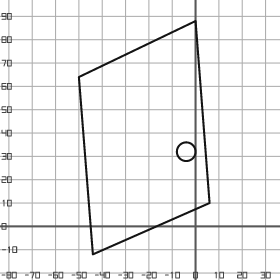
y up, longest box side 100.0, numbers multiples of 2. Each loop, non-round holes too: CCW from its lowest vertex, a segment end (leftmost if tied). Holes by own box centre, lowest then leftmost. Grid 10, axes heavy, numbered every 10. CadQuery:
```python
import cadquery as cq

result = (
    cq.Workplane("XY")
    .moveTo(-44.0, -12.0)
    .lineTo(6.0, 10.0)
    .lineTo(0.0, 88.0)
    .lineTo(-50.0, 64.0)
    .close()
    .moveTo(-4.0, 32.0)
    .circle(4.0)
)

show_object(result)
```